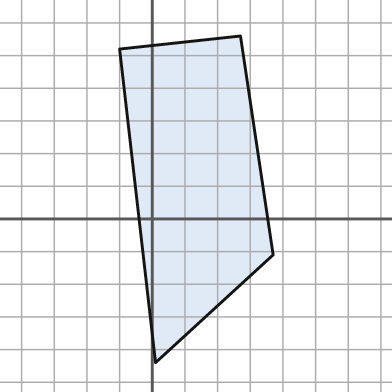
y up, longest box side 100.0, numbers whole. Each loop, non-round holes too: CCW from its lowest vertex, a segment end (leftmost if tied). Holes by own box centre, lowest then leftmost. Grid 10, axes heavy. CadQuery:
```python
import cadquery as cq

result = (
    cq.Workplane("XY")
    .moveTo(1.0, -44.0)
    .lineTo(37.0, -11.0)
    .lineTo(27.0, 56.0)
    .lineTo(-10.0, 52.0)
    .close()
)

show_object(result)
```